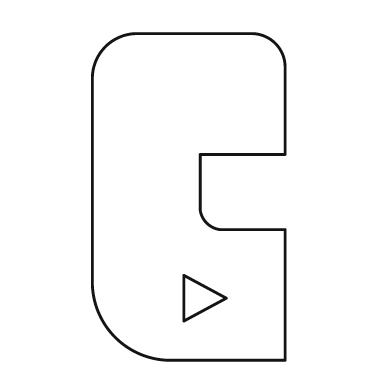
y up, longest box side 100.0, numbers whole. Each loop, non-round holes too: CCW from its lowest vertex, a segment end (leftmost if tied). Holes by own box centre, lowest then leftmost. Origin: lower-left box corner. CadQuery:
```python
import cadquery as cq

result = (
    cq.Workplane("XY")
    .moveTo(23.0, 0.0)
    .lineTo(59.0, 0.0)
    .lineTo(59.0, 40.0)
    .lineTo(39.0, 40.0)
    .threePointArc((35.0, 42.0), (33.0, 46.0))
    .lineTo(33.0, 63.0)
    .lineTo(59.0, 63.0)
    .lineTo(59.0, 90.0)
    .threePointArc((56.0, 97.0), (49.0, 100.0))
    .lineTo(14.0, 100.0)
    .threePointArc((4.0, 96.0), (0.0, 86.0))
    .lineTo(0.0, 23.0)
    .threePointArc((7.0, 7.0), (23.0, 0.0))
    .close()
    .moveTo(28.0, 12.0)
    .lineTo(41.0, 19.0)
    .lineTo(28.0, 26.0)
    .close()
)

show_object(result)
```